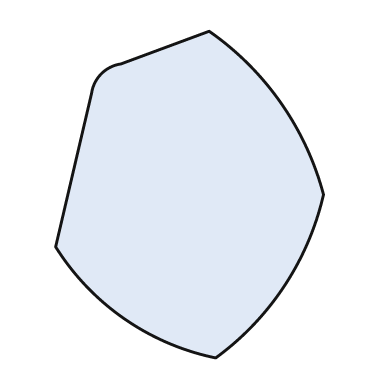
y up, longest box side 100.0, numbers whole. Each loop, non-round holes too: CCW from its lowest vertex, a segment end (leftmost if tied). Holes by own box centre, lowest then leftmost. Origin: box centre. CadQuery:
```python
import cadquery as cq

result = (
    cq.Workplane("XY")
    .moveTo(8.0, -50.0)
    .threePointArc((29.0, -28.0), (41.0, 0.0))
    .threePointArc((28.0, 28.0), (6.0, 50.0))
    .lineTo(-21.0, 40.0)
    .threePointArc((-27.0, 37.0), (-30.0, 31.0))
    .lineTo(-41.0, -16.0)
    .threePointArc((-20.0, -38.0), (8.0, -50.0))
    .close()
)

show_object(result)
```